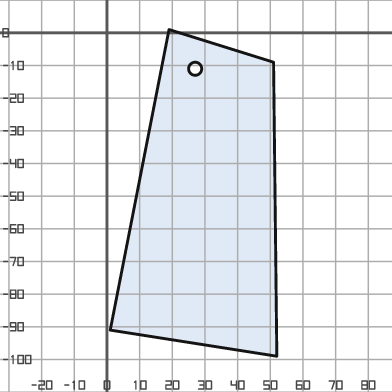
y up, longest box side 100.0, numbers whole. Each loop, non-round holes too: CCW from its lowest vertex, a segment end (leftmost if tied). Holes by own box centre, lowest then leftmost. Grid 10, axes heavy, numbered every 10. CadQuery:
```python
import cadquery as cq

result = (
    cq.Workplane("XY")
    .moveTo(52.0, -99.0)
    .lineTo(51.0, -9.0)
    .lineTo(19.0, 1.0)
    .lineTo(1.0, -91.0)
    .close()
    .moveTo(27.0, -11.0)
    .circle(2.0)
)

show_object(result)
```